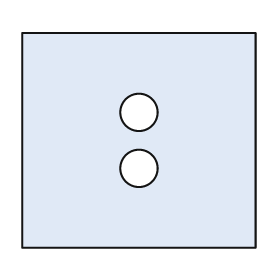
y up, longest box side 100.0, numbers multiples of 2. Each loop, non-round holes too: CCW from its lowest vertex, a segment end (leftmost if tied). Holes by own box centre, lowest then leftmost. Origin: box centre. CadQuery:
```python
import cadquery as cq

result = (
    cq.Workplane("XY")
    .moveTo(-50.0, -46.0)
    .lineTo(50.0, -46.0)
    .lineTo(50.0, 46.0)
    .lineTo(-50.0, 46.0)
    .close()
    .moveTo(0.0, -12.0)
    .circle(8.0)
    .moveTo(0.0, 12.0)
    .circle(8.0)
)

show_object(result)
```